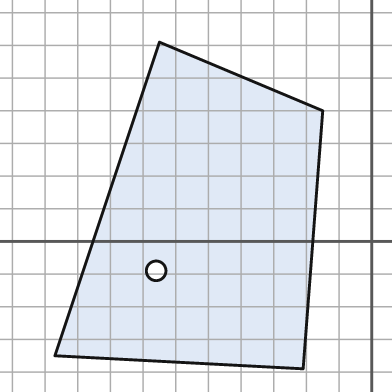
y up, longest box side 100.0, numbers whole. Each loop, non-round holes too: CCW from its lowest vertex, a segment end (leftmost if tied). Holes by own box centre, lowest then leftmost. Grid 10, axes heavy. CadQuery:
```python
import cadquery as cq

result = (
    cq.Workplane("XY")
    .moveTo(-21.0, -39.0)
    .lineTo(-15.0, 40.0)
    .lineTo(-65.0, 61.0)
    .lineTo(-97.0, -35.0)
    .close()
    .moveTo(-66.0, -9.0)
    .circle(3.0)
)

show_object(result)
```